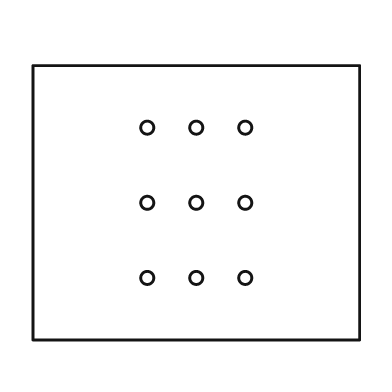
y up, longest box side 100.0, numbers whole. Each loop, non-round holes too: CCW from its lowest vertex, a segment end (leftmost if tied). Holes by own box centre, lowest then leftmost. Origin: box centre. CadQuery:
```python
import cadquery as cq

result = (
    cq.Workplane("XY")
    .moveTo(-50.0, -42.0)
    .lineTo(50.0, -42.0)
    .lineTo(50.0, 42.0)
    .lineTo(-50.0, 42.0)
    .close()
    .moveTo(-15.0, -23.0)
    .circle(2.0)
    .moveTo(0.0, -23.0)
    .circle(2.0)
    .moveTo(15.0, -23.0)
    .circle(2.0)
    .moveTo(-15.0, 0.0)
    .circle(2.0)
    .moveTo(0.0, 0.0)
    .circle(2.0)
    .moveTo(15.0, 0.0)
    .circle(2.0)
    .moveTo(-15.0, 23.0)
    .circle(2.0)
    .moveTo(0.0, 23.0)
    .circle(2.0)
    .moveTo(15.0, 23.0)
    .circle(2.0)
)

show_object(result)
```